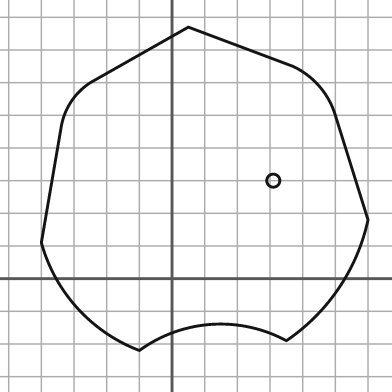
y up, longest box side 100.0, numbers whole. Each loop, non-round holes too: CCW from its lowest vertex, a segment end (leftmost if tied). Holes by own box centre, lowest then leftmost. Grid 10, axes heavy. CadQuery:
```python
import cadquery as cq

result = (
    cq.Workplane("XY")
    .moveTo(-10.0, -22.0)
    .threePointArc((12.0, -14.0), (35.0, -19.0))
    .threePointArc((51.0, -3.0), (60.0, 18.0))
    .lineTo(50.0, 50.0)
    .threePointArc((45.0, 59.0), (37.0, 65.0))
    .lineTo(5.0, 77.0)
    .lineTo(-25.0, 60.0)
    .threePointArc((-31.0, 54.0), (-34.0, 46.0))
    .lineTo(-40.0, 11.0)
    .threePointArc((-29.0, -9.0), (-10.0, -22.0))
    .close()
    .moveTo(31.0, 30.0)
    .circle(2.0)
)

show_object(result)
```